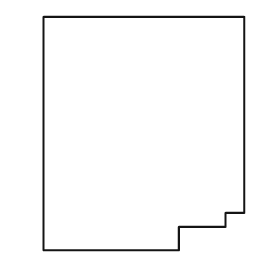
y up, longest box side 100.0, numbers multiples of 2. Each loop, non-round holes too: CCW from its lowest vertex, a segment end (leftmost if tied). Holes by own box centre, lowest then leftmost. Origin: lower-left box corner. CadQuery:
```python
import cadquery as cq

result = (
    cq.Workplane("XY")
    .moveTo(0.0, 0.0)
    .lineTo(58.0, 0.0)
    .lineTo(58.0, 10.0)
    .lineTo(78.0, 10.0)
    .lineTo(78.0, 16.0)
    .lineTo(86.0, 16.0)
    .lineTo(86.0, 100.0)
    .lineTo(0.0, 100.0)
    .close()
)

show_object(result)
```